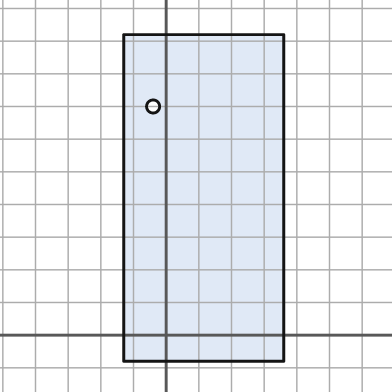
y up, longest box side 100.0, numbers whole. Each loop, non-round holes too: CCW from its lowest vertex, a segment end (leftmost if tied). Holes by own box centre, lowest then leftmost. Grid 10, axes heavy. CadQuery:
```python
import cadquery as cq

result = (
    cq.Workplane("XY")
    .moveTo(-13.0, -8.0)
    .lineTo(36.0, -8.0)
    .lineTo(36.0, 92.0)
    .lineTo(-13.0, 92.0)
    .close()
    .moveTo(-4.0, 70.0)
    .circle(2.0)
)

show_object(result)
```